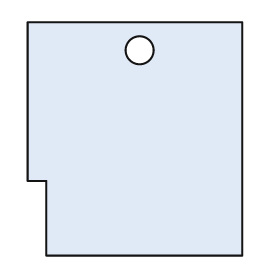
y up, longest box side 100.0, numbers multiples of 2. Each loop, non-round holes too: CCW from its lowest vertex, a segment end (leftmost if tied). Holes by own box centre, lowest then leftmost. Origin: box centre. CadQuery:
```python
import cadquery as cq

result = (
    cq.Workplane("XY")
    .moveTo(-38.0, -50.0)
    .lineTo(46.0, -50.0)
    .lineTo(46.0, 50.0)
    .lineTo(-46.0, 50.0)
    .lineTo(-46.0, -18.0)
    .lineTo(-38.0, -18.0)
    .close()
    .moveTo(2.0, 38.0)
    .circle(6.0)
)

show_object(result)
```